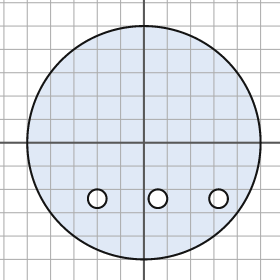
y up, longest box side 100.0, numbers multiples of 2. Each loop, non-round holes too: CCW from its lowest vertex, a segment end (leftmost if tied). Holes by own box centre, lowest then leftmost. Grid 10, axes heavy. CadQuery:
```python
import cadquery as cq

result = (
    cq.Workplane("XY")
    .moveTo(0.0, 0.0)
    .circle(50.0)
    .moveTo(-20.0, -24.0)
    .circle(4.0)
    .moveTo(6.0, -24.0)
    .circle(4.0)
    .moveTo(32.0, -24.0)
    .circle(4.0)
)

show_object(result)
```